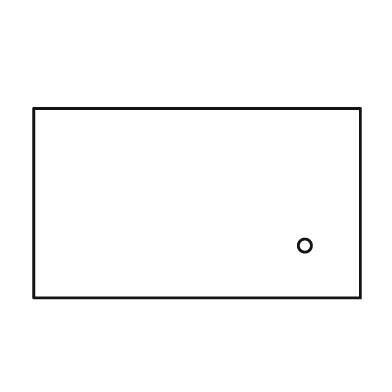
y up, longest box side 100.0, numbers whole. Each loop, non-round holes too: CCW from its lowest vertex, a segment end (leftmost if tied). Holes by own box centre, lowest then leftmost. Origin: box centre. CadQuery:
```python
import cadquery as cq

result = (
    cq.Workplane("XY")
    .moveTo(-50.0, -29.0)
    .lineTo(50.0, -29.0)
    .lineTo(50.0, 29.0)
    .lineTo(-50.0, 29.0)
    .close()
    .moveTo(33.0, -13.0)
    .circle(2.0)
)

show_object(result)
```